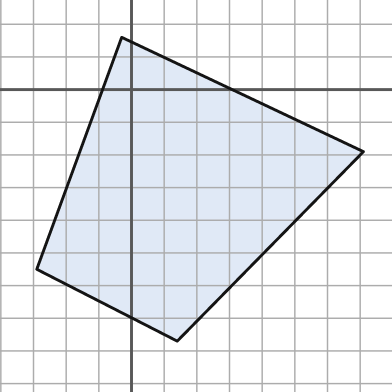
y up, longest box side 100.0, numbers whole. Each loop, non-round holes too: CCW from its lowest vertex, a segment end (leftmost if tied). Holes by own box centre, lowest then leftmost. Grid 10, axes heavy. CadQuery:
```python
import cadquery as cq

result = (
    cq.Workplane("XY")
    .moveTo(14.0, -77.0)
    .lineTo(71.0, -19.0)
    .lineTo(-3.0, 16.0)
    .lineTo(-29.0, -55.0)
    .close()
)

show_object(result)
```